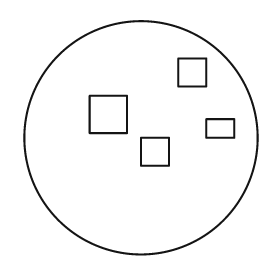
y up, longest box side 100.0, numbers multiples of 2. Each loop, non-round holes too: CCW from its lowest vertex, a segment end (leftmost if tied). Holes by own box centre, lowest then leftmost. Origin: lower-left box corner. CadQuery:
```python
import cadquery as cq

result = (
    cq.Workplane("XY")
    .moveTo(50.0, 50.0)
    .circle(50.0)
    .moveTo(50.0, 38.0)
    .lineTo(62.0, 38.0)
    .lineTo(62.0, 50.0)
    .lineTo(50.0, 50.0)
    .close()
    .moveTo(78.0, 50.0)
    .lineTo(90.0, 50.0)
    .lineTo(90.0, 58.0)
    .lineTo(78.0, 58.0)
    .close()
    .moveTo(28.0, 52.0)
    .lineTo(44.0, 52.0)
    .lineTo(44.0, 68.0)
    .lineTo(28.0, 68.0)
    .close()
    .moveTo(66.0, 72.0)
    .lineTo(78.0, 72.0)
    .lineTo(78.0, 84.0)
    .lineTo(66.0, 84.0)
    .close()
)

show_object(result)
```